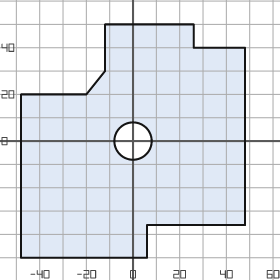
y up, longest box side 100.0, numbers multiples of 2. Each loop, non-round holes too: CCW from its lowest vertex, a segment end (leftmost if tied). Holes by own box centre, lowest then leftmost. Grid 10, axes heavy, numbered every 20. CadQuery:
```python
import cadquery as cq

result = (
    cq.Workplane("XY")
    .moveTo(-48.0, -50.0)
    .lineTo(6.0, -50.0)
    .lineTo(6.0, -36.0)
    .lineTo(48.0, -36.0)
    .lineTo(48.0, 40.0)
    .lineTo(26.0, 40.0)
    .lineTo(26.0, 50.0)
    .lineTo(-12.0, 50.0)
    .lineTo(-12.0, 30.0)
    .lineTo(-20.0, 20.0)
    .lineTo(-48.0, 20.0)
    .close()
    .moveTo(0.0, 0.0)
    .circle(8.0)
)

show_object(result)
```